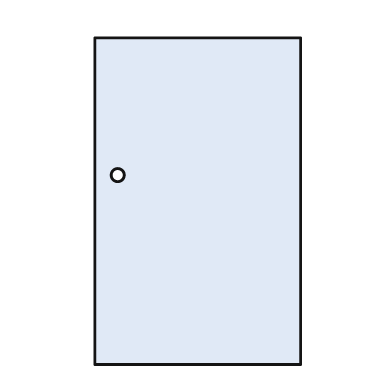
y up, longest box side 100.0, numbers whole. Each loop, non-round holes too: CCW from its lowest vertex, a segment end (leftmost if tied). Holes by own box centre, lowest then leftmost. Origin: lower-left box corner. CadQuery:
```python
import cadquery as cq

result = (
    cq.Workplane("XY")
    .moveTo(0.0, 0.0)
    .lineTo(63.0, 0.0)
    .lineTo(63.0, 100.0)
    .lineTo(0.0, 100.0)
    .close()
    .moveTo(7.0, 58.0)
    .circle(2.0)
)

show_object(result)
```